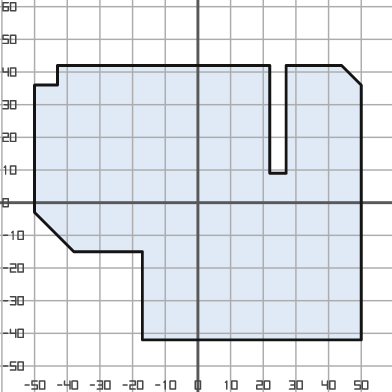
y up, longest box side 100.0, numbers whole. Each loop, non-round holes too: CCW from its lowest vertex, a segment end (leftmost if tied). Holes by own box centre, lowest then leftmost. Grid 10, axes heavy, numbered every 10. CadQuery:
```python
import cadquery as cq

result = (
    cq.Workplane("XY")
    .moveTo(-17.0, -42.0)
    .lineTo(50.0, -42.0)
    .lineTo(50.0, 36.0)
    .lineTo(44.0, 42.0)
    .lineTo(27.0, 42.0)
    .lineTo(27.0, 9.0)
    .lineTo(22.0, 9.0)
    .lineTo(22.0, 42.0)
    .lineTo(-43.0, 42.0)
    .lineTo(-43.0, 36.0)
    .lineTo(-50.0, 36.0)
    .lineTo(-50.0, -3.0)
    .lineTo(-38.0, -15.0)
    .lineTo(-17.0, -15.0)
    .close()
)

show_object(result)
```